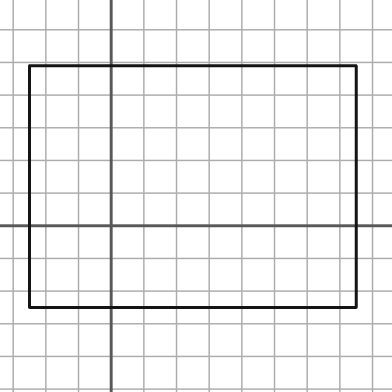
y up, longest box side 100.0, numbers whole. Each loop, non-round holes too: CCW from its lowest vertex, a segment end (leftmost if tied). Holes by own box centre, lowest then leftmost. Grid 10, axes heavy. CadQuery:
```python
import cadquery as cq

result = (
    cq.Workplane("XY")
    .moveTo(-25.0, -25.0)
    .lineTo(75.0, -25.0)
    .lineTo(75.0, 49.0)
    .lineTo(-25.0, 49.0)
    .close()
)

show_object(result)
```